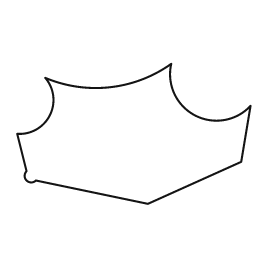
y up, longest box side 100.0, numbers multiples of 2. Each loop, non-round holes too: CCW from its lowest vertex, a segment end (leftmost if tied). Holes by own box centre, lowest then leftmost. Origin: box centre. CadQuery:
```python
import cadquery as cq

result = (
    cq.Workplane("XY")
    .moveTo(6.0, -30.0)
    .lineTo(46.0, -12.0)
    .lineTo(50.0, 12.0)
    .threePointArc((26.0, 8.0), (16.0, 30.0))
    .threePointArc((-10.0, 20.0), (-38.0, 24.0))
    .threePointArc((-36.0, 8.0), (-50.0, 0.0))
    .lineTo(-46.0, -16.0)
    .threePointArc((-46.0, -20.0), (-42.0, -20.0))
    .close()
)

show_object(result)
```